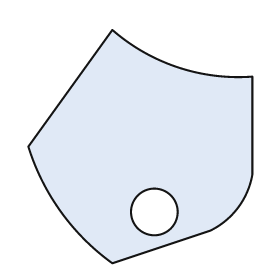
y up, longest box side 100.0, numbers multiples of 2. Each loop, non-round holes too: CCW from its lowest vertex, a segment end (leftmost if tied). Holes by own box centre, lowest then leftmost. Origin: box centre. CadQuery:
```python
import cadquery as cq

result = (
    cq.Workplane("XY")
    .moveTo(-12.0, -50.0)
    .lineTo(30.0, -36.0)
    .threePointArc((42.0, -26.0), (48.0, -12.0))
    .lineTo(48.0, 30.0)
    .threePointArc((16.0, 34.0), (-12.0, 50.0))
    .lineTo(-48.0, 0.0)
    .threePointArc((-34.0, -28.0), (-12.0, -50.0))
    .close()
    .moveTo(6.0, -28.0)
    .circle(10.0)
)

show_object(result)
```